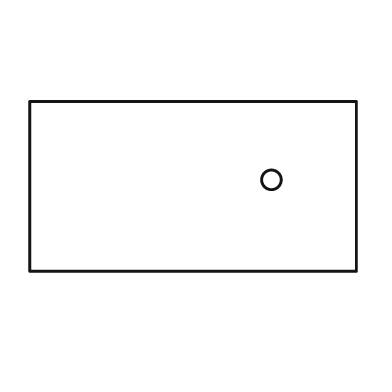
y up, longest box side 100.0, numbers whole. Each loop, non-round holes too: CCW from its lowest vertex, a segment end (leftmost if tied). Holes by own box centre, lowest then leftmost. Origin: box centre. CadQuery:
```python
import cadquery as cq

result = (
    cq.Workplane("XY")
    .moveTo(-50.0, -26.0)
    .lineTo(50.0, -26.0)
    .lineTo(50.0, 26.0)
    .lineTo(-50.0, 26.0)
    .close()
    .moveTo(24.0, 2.0)
    .circle(3.0)
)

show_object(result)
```